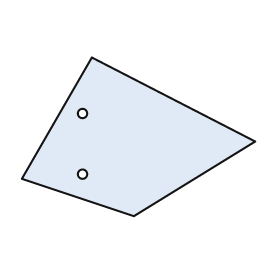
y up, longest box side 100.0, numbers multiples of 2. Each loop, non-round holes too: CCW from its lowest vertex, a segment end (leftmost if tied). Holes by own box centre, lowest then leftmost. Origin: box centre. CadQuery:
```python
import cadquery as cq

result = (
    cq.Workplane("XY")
    .moveTo(-2.0, -34.0)
    .lineTo(50.0, -2.0)
    .lineTo(-20.0, 34.0)
    .lineTo(-50.0, -18.0)
    .close()
    .moveTo(-24.0, -16.0)
    .circle(2.0)
    .moveTo(-24.0, 10.0)
    .circle(2.0)
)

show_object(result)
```